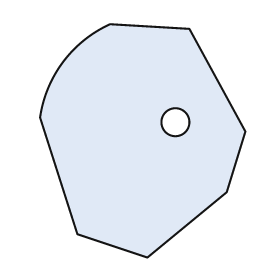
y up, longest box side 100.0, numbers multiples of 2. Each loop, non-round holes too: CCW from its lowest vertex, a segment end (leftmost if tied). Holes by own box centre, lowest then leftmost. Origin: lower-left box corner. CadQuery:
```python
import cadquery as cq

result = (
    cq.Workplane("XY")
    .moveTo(46.0, 0.0)
    .lineTo(80.0, 28.0)
    .lineTo(88.0, 54.0)
    .lineTo(64.0, 98.0)
    .lineTo(30.0, 100.0)
    .threePointArc((10.0, 84.0), (0.0, 60.0))
    .lineTo(16.0, 10.0)
    .close()
    .moveTo(58.0, 58.0)
    .circle(6.0)
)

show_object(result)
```